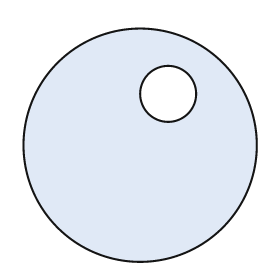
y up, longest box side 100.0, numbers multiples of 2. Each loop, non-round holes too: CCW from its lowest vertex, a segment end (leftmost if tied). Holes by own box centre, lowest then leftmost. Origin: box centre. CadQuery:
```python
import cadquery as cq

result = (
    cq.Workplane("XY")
    .moveTo(0.0, 0.0)
    .circle(50.0)
    .moveTo(12.0, 22.0)
    .circle(12.0)
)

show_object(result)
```